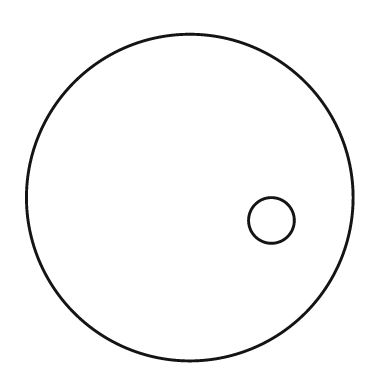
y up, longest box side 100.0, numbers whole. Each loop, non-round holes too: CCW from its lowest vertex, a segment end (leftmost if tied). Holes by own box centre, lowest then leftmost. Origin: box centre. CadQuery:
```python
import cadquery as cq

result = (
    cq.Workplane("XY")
    .moveTo(0.0, 0.0)
    .circle(50.0)
    .moveTo(25.0, -7.0)
    .circle(7.0)
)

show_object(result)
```